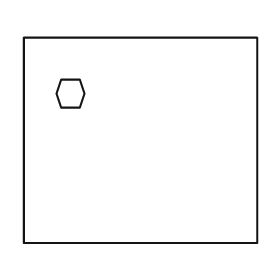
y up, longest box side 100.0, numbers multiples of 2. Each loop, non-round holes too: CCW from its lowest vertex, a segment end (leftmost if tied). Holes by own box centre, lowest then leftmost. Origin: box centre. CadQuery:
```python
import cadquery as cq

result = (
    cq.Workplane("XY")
    .moveTo(-50.0, -44.0)
    .lineTo(50.0, -44.0)
    .lineTo(50.0, 44.0)
    .lineTo(-50.0, 44.0)
    .close()
    .moveTo(-34.0, 14.0)
    .lineTo(-26.0, 14.0)
    .lineTo(-24.0, 20.0)
    .lineTo(-26.0, 26.0)
    .lineTo(-34.0, 26.0)
    .lineTo(-36.0, 20.0)
    .close()
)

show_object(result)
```